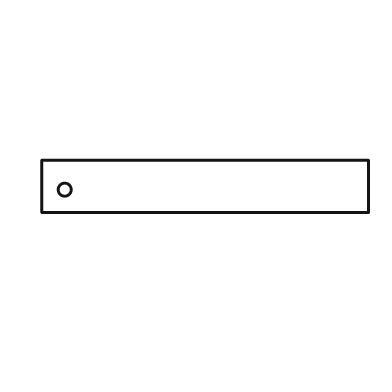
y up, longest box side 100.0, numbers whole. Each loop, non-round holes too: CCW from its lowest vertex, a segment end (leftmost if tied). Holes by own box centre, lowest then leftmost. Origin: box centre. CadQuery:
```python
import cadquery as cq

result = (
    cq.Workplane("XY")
    .moveTo(-50.0, -8.0)
    .lineTo(50.0, -8.0)
    .lineTo(50.0, 8.0)
    .lineTo(-50.0, 8.0)
    .close()
    .moveTo(-43.0, -1.0)
    .circle(2.0)
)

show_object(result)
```